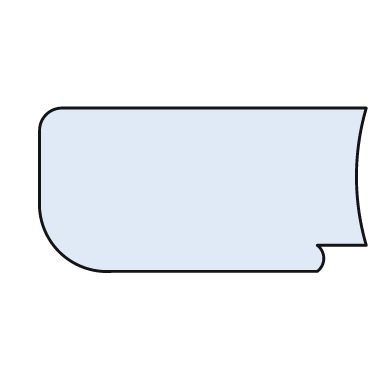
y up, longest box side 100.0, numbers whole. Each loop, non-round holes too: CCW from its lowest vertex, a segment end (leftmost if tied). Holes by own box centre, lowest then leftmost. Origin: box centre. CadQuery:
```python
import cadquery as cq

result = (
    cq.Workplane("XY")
    .moveTo(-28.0, -25.0)
    .lineTo(35.0, -25.0)
    .threePointArc((37.0, -21.0), (35.0, -17.0))
    .lineTo(50.0, -17.0)
    .threePointArc((47.0, 4.0), (50.0, 25.0))
    .lineTo(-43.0, 25.0)
    .threePointArc((-48.0, 23.0), (-50.0, 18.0))
    .lineTo(-50.0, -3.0)
    .threePointArc((-44.0, -19.0), (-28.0, -25.0))
    .close()
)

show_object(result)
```